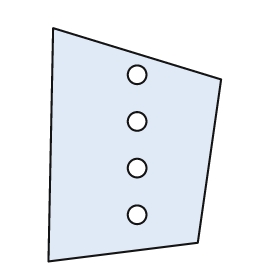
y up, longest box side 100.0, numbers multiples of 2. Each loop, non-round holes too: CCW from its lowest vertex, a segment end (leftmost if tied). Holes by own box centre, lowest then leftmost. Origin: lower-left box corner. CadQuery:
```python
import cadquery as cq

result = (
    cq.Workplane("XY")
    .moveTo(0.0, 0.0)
    .lineTo(64.0, 8.0)
    .lineTo(74.0, 78.0)
    .lineTo(2.0, 100.0)
    .close()
    .moveTo(38.0, 20.0)
    .circle(4.0)
    .moveTo(38.0, 40.0)
    .circle(4.0)
    .moveTo(38.0, 60.0)
    .circle(4.0)
    .moveTo(38.0, 80.0)
    .circle(4.0)
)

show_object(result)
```